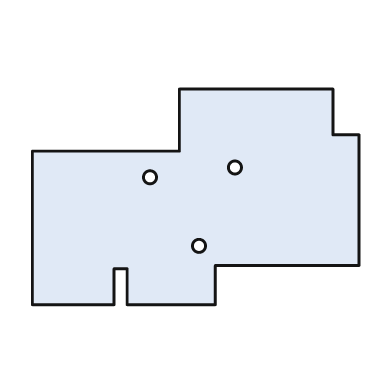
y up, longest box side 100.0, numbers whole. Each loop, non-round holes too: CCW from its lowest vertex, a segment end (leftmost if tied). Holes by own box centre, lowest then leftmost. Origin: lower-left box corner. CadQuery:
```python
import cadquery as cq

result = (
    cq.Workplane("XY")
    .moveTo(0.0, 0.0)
    .lineTo(25.0, 0.0)
    .lineTo(25.0, 11.0)
    .lineTo(29.0, 11.0)
    .lineTo(29.0, 0.0)
    .lineTo(56.0, 0.0)
    .lineTo(56.0, 12.0)
    .lineTo(100.0, 12.0)
    .lineTo(100.0, 52.0)
    .lineTo(92.0, 52.0)
    .lineTo(92.0, 66.0)
    .lineTo(45.0, 66.0)
    .lineTo(45.0, 47.0)
    .lineTo(0.0, 47.0)
    .close()
    .moveTo(51.0, 18.0)
    .circle(2.0)
    .moveTo(36.0, 39.0)
    .circle(2.0)
    .moveTo(62.0, 42.0)
    .circle(2.0)
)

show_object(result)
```